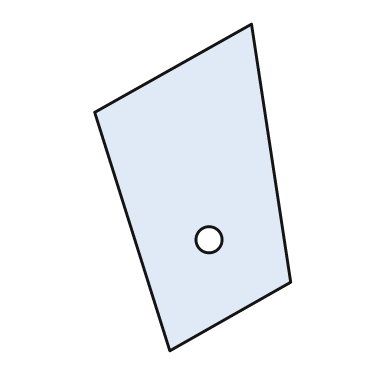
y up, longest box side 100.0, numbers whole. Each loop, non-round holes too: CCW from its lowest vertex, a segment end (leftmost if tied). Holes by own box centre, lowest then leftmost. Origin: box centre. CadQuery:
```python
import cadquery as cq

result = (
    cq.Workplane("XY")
    .moveTo(-7.0, -50.0)
    .lineTo(30.0, -29.0)
    .lineTo(18.0, 50.0)
    .lineTo(-30.0, 23.0)
    .close()
    .moveTo(5.0, -16.0)
    .circle(4.0)
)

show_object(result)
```